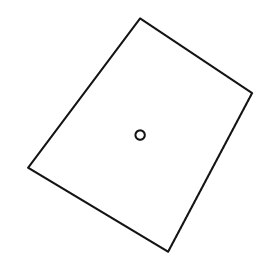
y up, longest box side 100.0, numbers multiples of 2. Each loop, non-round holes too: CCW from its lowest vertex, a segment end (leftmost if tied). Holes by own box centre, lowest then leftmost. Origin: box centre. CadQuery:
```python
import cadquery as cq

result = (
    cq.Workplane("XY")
    .moveTo(12.0, -50.0)
    .lineTo(48.0, 18.0)
    .lineTo(0.0, 50.0)
    .lineTo(-48.0, -14.0)
    .close()
    .moveTo(0.0, 0.0)
    .circle(2.0)
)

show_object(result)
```